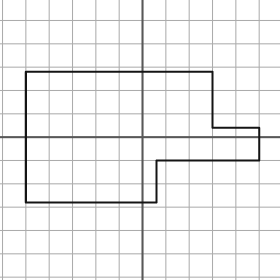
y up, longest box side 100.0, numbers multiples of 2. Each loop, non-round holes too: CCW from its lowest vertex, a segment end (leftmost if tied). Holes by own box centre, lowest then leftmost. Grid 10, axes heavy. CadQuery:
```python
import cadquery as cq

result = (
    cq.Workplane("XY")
    .moveTo(-50.0, -28.0)
    .lineTo(6.0, -28.0)
    .lineTo(6.0, -10.0)
    .lineTo(50.0, -10.0)
    .lineTo(50.0, 4.0)
    .lineTo(30.0, 4.0)
    .lineTo(30.0, 28.0)
    .lineTo(-50.0, 28.0)
    .close()
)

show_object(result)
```